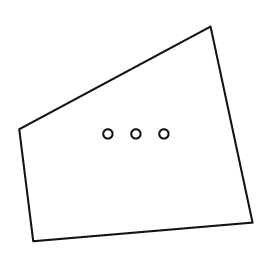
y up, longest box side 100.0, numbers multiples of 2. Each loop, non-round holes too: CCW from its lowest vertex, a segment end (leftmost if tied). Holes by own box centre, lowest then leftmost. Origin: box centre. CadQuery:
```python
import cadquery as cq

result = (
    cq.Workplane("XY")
    .moveTo(-44.0, -46.0)
    .lineTo(50.0, -38.0)
    .lineTo(32.0, 46.0)
    .lineTo(-50.0, 2.0)
    .close()
    .moveTo(-12.0, 0.0)
    .circle(2.0)
    .moveTo(0.0, 0.0)
    .circle(2.0)
    .moveTo(12.0, 0.0)
    .circle(2.0)
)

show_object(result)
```